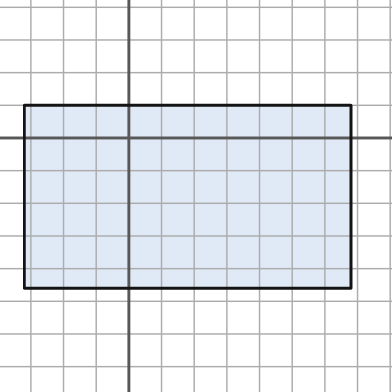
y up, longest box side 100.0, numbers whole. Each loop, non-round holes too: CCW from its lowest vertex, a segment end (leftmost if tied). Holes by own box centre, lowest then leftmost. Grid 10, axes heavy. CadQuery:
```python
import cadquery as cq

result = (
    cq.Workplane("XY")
    .moveTo(-32.0, -46.0)
    .lineTo(68.0, -46.0)
    .lineTo(68.0, 10.0)
    .lineTo(-32.0, 10.0)
    .close()
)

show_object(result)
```